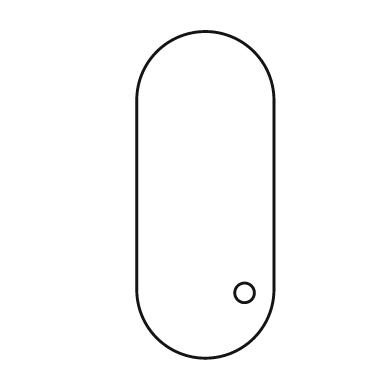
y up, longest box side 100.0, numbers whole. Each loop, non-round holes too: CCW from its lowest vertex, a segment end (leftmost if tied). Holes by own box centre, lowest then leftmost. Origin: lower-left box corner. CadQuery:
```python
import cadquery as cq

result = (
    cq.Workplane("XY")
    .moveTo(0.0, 21.0)
    .threePointArc((21.0, 0.0), (42.0, 21.0))
    .lineTo(42.0, 79.0)
    .threePointArc((21.0, 100.0), (0.0, 79.0))
    .close()
    .moveTo(33.0, 20.0)
    .circle(3.0)
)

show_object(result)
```